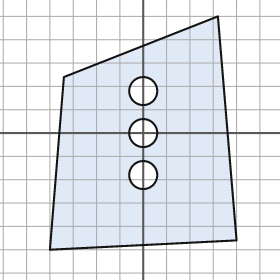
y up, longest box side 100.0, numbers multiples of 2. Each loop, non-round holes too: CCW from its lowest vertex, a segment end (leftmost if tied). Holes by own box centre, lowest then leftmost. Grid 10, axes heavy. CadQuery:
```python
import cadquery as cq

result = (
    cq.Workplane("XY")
    .moveTo(-40.0, -50.0)
    .lineTo(40.0, -46.0)
    .lineTo(32.0, 50.0)
    .lineTo(-34.0, 24.0)
    .close()
    .moveTo(0.0, -18.0)
    .circle(6.0)
    .moveTo(0.0, 0.0)
    .circle(6.0)
    .moveTo(0.0, 18.0)
    .circle(6.0)
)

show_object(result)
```